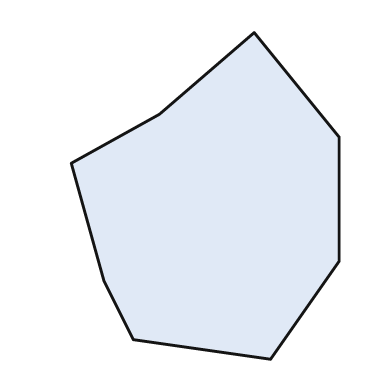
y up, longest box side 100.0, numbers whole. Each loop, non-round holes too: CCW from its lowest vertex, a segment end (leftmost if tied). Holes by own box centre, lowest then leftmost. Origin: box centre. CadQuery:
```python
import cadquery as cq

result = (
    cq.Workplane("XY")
    .moveTo(20.0, -50.0)
    .lineTo(41.0, -20.0)
    .lineTo(41.0, 18.0)
    .lineTo(15.0, 50.0)
    .lineTo(-14.0, 25.0)
    .lineTo(-41.0, 10.0)
    .lineTo(-31.0, -26.0)
    .lineTo(-22.0, -44.0)
    .close()
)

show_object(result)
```